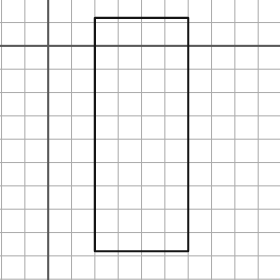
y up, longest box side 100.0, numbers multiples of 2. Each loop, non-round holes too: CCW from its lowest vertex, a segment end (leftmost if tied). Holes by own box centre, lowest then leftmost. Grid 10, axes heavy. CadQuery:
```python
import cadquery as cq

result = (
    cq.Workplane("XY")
    .moveTo(20.0, -88.0)
    .lineTo(60.0, -88.0)
    .lineTo(60.0, 12.0)
    .lineTo(20.0, 12.0)
    .close()
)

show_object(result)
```